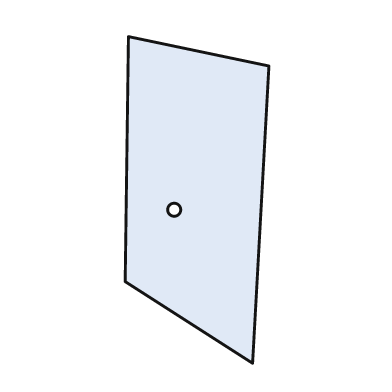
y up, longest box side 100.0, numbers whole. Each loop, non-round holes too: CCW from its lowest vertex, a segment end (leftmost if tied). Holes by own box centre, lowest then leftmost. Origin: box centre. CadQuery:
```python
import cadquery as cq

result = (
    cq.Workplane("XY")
    .moveTo(17.0, -50.0)
    .lineTo(22.0, 41.0)
    .lineTo(-21.0, 50.0)
    .lineTo(-22.0, -25.0)
    .close()
    .moveTo(-7.0, -3.0)
    .circle(2.0)
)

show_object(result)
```